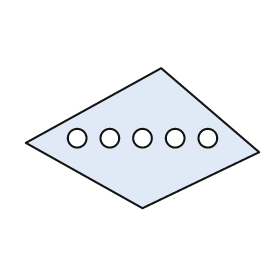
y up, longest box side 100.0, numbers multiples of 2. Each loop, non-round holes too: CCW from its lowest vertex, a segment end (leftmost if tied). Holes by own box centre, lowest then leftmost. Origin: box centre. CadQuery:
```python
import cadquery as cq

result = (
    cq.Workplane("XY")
    .moveTo(0.0, -30.0)
    .lineTo(50.0, -6.0)
    .lineTo(8.0, 30.0)
    .lineTo(-50.0, -2.0)
    .close()
    .moveTo(-28.0, 0.0)
    .circle(4.0)
    .moveTo(-14.0, 0.0)
    .circle(4.0)
    .moveTo(0.0, 0.0)
    .circle(4.0)
    .moveTo(14.0, 0.0)
    .circle(4.0)
    .moveTo(28.0, 0.0)
    .circle(4.0)
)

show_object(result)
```